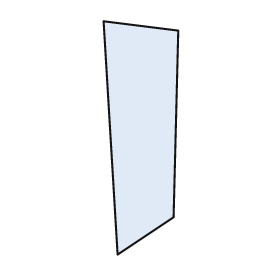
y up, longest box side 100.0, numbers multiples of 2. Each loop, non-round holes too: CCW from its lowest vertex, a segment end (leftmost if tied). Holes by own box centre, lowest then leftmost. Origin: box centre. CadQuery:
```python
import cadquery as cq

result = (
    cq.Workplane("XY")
    .moveTo(-10.0, -50.0)
    .lineTo(14.0, -34.0)
    .lineTo(16.0, 46.0)
    .lineTo(-16.0, 50.0)
    .close()
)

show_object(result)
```